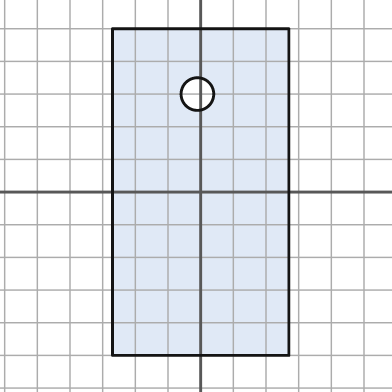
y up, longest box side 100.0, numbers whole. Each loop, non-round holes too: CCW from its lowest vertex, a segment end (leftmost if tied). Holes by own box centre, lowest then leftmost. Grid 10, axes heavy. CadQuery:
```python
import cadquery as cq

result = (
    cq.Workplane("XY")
    .moveTo(-27.0, -50.0)
    .lineTo(27.0, -50.0)
    .lineTo(27.0, 50.0)
    .lineTo(-27.0, 50.0)
    .close()
    .moveTo(-1.0, 30.0)
    .circle(5.0)
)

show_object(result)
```